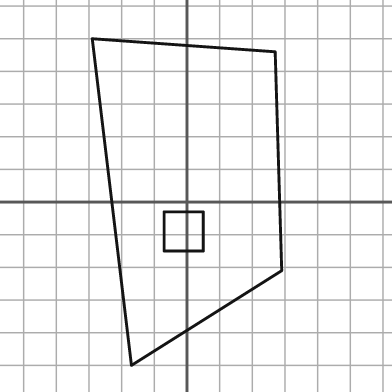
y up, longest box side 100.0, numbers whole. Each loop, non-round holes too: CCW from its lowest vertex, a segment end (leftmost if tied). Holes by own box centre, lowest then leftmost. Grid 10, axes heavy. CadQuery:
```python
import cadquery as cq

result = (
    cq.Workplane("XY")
    .moveTo(-17.0, -50.0)
    .lineTo(29.0, -21.0)
    .lineTo(27.0, 46.0)
    .lineTo(-29.0, 50.0)
    .close()
    .moveTo(-7.0, -15.0)
    .lineTo(5.0, -15.0)
    .lineTo(5.0, -3.0)
    .lineTo(-7.0, -3.0)
    .close()
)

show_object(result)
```